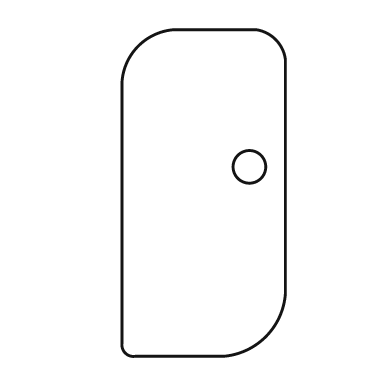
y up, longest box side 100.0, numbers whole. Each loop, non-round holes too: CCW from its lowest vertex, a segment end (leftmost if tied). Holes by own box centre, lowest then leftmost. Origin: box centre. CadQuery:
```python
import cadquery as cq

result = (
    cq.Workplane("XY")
    .moveTo(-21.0, -50.0)
    .lineTo(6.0, -50.0)
    .threePointArc((19.0, -44.0), (25.0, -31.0))
    .lineTo(25.0, 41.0)
    .threePointArc((22.0, 47.0), (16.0, 50.0))
    .lineTo(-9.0, 50.0)
    .threePointArc((-20.0, 45.0), (-25.0, 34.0))
    .lineTo(-25.0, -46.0)
    .threePointArc((-24.0, -49.0), (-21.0, -50.0))
    .close()
    .moveTo(14.0, 8.0)
    .circle(5.0)
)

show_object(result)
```